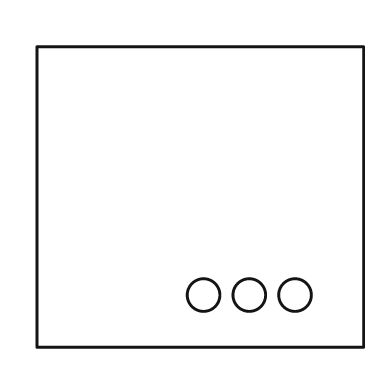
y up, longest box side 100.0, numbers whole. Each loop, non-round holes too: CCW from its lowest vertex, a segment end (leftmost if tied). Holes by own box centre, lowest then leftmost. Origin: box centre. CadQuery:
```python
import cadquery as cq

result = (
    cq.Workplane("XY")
    .moveTo(-50.0, -46.0)
    .lineTo(50.0, -46.0)
    .lineTo(50.0, 46.0)
    .lineTo(-50.0, 46.0)
    .close()
    .moveTo(1.0, -30.0)
    .circle(5.0)
    .moveTo(15.0, -30.0)
    .circle(5.0)
    .moveTo(29.0, -30.0)
    .circle(5.0)
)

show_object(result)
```